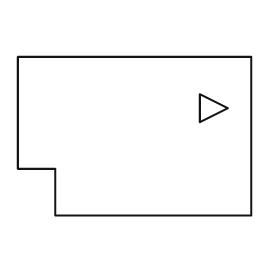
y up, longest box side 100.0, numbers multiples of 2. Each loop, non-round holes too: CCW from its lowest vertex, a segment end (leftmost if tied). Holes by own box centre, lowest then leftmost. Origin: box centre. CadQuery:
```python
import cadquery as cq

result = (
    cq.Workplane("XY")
    .moveTo(-34.0, -34.0)
    .lineTo(50.0, -34.0)
    .lineTo(50.0, 34.0)
    .lineTo(-50.0, 34.0)
    .lineTo(-50.0, -14.0)
    .lineTo(-34.0, -14.0)
    .close()
    .moveTo(28.0, 6.0)
    .lineTo(40.0, 12.0)
    .lineTo(28.0, 18.0)
    .close()
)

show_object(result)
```